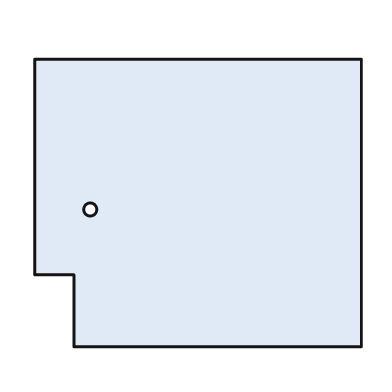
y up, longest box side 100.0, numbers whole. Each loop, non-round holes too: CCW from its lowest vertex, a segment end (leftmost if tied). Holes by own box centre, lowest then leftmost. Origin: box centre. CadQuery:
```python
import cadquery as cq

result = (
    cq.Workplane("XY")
    .moveTo(-38.0, -44.0)
    .lineTo(50.0, -44.0)
    .lineTo(50.0, 44.0)
    .lineTo(-50.0, 44.0)
    .lineTo(-50.0, -22.0)
    .lineTo(-38.0, -22.0)
    .close()
    .moveTo(-33.0, -2.0)
    .circle(2.0)
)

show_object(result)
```